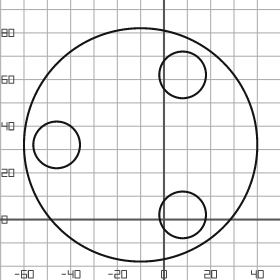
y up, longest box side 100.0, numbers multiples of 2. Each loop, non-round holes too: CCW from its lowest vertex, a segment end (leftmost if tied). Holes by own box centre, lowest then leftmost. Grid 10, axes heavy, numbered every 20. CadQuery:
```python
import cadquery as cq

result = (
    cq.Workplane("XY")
    .moveTo(-10.0, 32.0)
    .circle(50.0)
    .moveTo(8.0, 2.0)
    .circle(10.0)
    .moveTo(-46.0, 32.0)
    .circle(10.0)
    .moveTo(8.0, 62.0)
    .circle(10.0)
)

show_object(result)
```